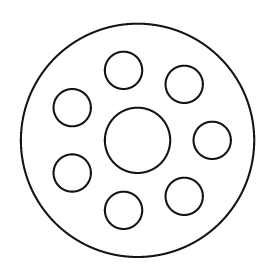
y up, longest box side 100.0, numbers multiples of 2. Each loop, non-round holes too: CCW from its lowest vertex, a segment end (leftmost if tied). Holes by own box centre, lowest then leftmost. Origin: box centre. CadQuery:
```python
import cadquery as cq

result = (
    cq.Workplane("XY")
    .moveTo(0.0, 0.0)
    .circle(50.0)
    .moveTo(-6.0, -30.0)
    .circle(8.0)
    .moveTo(20.0, -24.0)
    .circle(8.0)
    .moveTo(-28.0, -14.0)
    .circle(8.0)
    .moveTo(0.0, 0.0)
    .circle(14.0)
    .moveTo(32.0, 0.0)
    .circle(8.0)
    .moveTo(-28.0, 14.0)
    .circle(8.0)
    .moveTo(20.0, 24.0)
    .circle(8.0)
    .moveTo(-6.0, 30.0)
    .circle(8.0)
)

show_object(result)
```